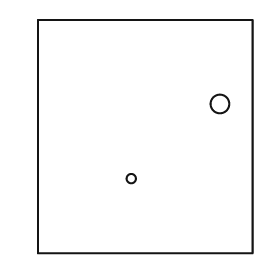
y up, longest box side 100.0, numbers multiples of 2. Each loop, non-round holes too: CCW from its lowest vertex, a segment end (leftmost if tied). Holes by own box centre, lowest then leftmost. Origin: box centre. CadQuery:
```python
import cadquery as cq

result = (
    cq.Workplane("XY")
    .moveTo(-46.0, -50.0)
    .lineTo(46.0, -50.0)
    .lineTo(46.0, 50.0)
    .lineTo(-46.0, 50.0)
    .close()
    .moveTo(-6.0, -18.0)
    .circle(2.0)
    .moveTo(32.0, 14.0)
    .circle(4.0)
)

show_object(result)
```